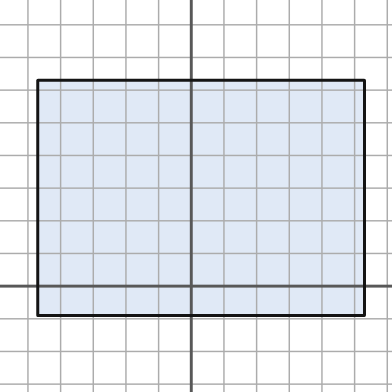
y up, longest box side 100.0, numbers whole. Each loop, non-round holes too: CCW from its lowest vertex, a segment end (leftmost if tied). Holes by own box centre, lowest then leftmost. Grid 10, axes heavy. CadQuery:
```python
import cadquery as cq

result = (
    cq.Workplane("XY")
    .moveTo(-47.0, -9.0)
    .lineTo(53.0, -9.0)
    .lineTo(53.0, 63.0)
    .lineTo(-47.0, 63.0)
    .close()
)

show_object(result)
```